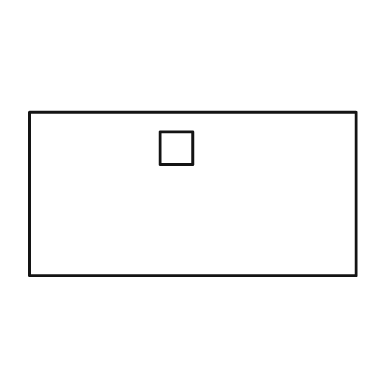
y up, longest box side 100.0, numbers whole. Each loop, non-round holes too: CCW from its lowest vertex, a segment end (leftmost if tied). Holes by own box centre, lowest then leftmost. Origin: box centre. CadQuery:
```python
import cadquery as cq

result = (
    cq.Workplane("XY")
    .moveTo(-50.0, -25.0)
    .lineTo(50.0, -25.0)
    .lineTo(50.0, 25.0)
    .lineTo(-50.0, 25.0)
    .close()
    .moveTo(-10.0, 9.0)
    .lineTo(0.0, 9.0)
    .lineTo(0.0, 19.0)
    .lineTo(-10.0, 19.0)
    .close()
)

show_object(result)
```